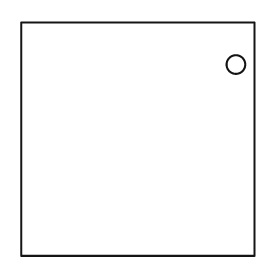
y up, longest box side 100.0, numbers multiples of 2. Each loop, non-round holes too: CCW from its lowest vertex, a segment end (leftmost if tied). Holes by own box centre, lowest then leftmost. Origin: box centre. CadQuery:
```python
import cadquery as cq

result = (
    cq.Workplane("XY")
    .moveTo(-50.0, -50.0)
    .lineTo(50.0, -50.0)
    .lineTo(50.0, 50.0)
    .lineTo(-50.0, 50.0)
    .close()
    .moveTo(42.0, 32.0)
    .circle(4.0)
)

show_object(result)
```